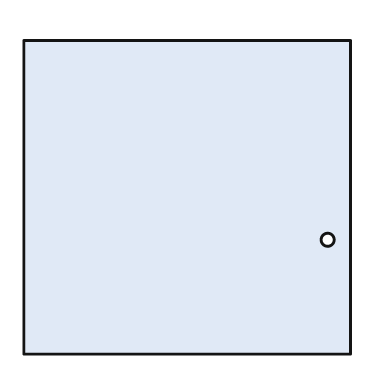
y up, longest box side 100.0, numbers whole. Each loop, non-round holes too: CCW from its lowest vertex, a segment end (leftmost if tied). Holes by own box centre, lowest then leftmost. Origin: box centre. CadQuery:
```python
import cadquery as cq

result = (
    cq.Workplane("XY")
    .moveTo(-50.0, -48.0)
    .lineTo(50.0, -48.0)
    .lineTo(50.0, 48.0)
    .lineTo(-50.0, 48.0)
    .close()
    .moveTo(43.0, -13.0)
    .circle(2.0)
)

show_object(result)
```